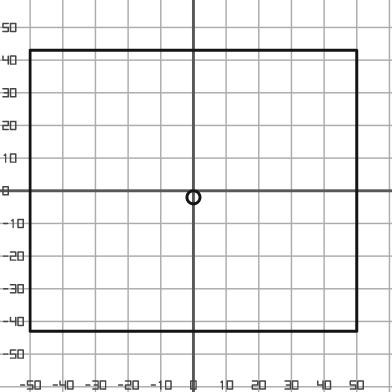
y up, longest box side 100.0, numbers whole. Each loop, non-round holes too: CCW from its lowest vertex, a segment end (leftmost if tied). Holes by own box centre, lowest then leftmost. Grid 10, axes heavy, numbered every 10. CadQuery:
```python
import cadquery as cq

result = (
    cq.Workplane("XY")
    .moveTo(-50.0, -43.0)
    .lineTo(50.0, -43.0)
    .lineTo(50.0, 43.0)
    .lineTo(-50.0, 43.0)
    .close()
    .moveTo(0.0, -2.0)
    .circle(2.0)
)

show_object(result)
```